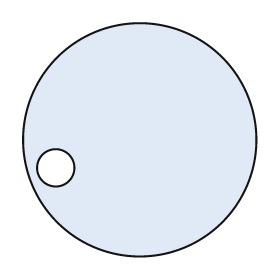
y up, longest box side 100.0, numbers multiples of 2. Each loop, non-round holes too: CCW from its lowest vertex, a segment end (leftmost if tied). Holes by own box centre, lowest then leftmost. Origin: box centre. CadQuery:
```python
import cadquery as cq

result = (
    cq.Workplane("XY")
    .moveTo(0.0, 0.0)
    .circle(50.0)
    .moveTo(-36.0, -12.0)
    .circle(8.0)
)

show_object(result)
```